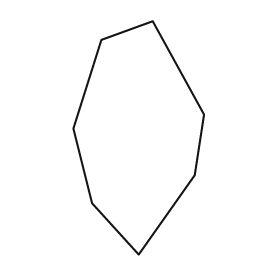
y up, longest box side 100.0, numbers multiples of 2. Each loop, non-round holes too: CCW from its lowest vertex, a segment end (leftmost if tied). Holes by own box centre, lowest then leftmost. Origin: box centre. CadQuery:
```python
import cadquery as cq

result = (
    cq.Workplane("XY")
    .moveTo(0.0, -50.0)
    .lineTo(24.0, -16.0)
    .lineTo(28.0, 10.0)
    .lineTo(6.0, 50.0)
    .lineTo(-16.0, 42.0)
    .lineTo(-28.0, 4.0)
    .lineTo(-20.0, -28.0)
    .close()
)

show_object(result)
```